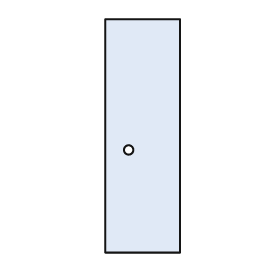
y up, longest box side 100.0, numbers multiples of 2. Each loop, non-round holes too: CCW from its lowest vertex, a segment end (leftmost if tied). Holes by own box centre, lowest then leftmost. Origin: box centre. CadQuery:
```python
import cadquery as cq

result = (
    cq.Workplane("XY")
    .moveTo(-16.0, -50.0)
    .lineTo(16.0, -50.0)
    .lineTo(16.0, 50.0)
    .lineTo(-16.0, 50.0)
    .close()
    .moveTo(-6.0, -6.0)
    .circle(2.0)
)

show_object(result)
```